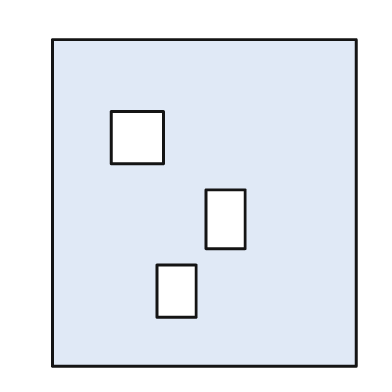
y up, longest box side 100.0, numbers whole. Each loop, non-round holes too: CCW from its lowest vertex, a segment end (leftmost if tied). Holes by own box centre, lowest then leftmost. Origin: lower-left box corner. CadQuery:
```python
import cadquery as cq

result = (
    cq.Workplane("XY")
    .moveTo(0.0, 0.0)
    .lineTo(93.0, 0.0)
    .lineTo(93.0, 100.0)
    .lineTo(0.0, 100.0)
    .close()
    .moveTo(32.0, 15.0)
    .lineTo(44.0, 15.0)
    .lineTo(44.0, 31.0)
    .lineTo(32.0, 31.0)
    .close()
    .moveTo(47.0, 36.0)
    .lineTo(59.0, 36.0)
    .lineTo(59.0, 54.0)
    .lineTo(47.0, 54.0)
    .close()
    .moveTo(18.0, 62.0)
    .lineTo(34.0, 62.0)
    .lineTo(34.0, 78.0)
    .lineTo(18.0, 78.0)
    .close()
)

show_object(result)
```